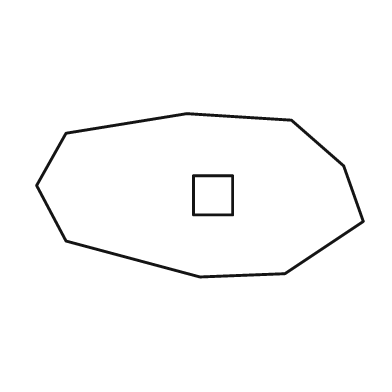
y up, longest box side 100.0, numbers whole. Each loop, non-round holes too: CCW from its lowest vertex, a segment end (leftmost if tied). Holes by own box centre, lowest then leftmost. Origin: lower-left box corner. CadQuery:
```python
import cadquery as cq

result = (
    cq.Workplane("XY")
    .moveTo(50.0, 0.0)
    .lineTo(76.0, 1.0)
    .lineTo(100.0, 17.0)
    .lineTo(94.0, 34.0)
    .lineTo(78.0, 48.0)
    .lineTo(46.0, 50.0)
    .lineTo(9.0, 44.0)
    .lineTo(0.0, 28.0)
    .lineTo(9.0, 11.0)
    .close()
    .moveTo(48.0, 19.0)
    .lineTo(60.0, 19.0)
    .lineTo(60.0, 31.0)
    .lineTo(48.0, 31.0)
    .close()
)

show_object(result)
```